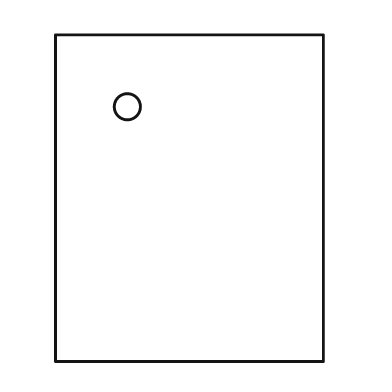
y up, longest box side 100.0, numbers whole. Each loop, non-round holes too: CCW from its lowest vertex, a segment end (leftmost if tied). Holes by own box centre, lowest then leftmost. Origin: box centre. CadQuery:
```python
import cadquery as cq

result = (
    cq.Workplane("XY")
    .moveTo(-41.0, -50.0)
    .lineTo(41.0, -50.0)
    .lineTo(41.0, 50.0)
    .lineTo(-41.0, 50.0)
    .close()
    .moveTo(-19.0, 28.0)
    .circle(4.0)
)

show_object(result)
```